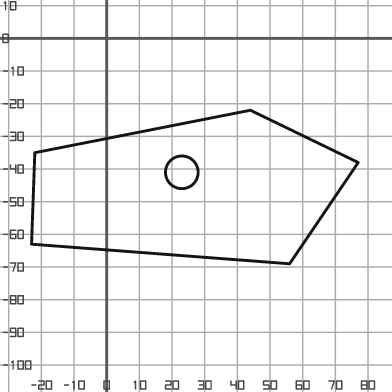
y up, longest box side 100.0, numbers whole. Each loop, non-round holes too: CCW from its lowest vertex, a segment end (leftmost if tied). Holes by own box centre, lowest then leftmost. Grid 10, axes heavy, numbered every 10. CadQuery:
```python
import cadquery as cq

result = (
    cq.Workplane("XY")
    .moveTo(56.0, -69.0)
    .lineTo(77.0, -38.0)
    .lineTo(44.0, -22.0)
    .lineTo(-22.0, -35.0)
    .lineTo(-23.0, -63.0)
    .close()
    .moveTo(23.0, -41.0)
    .circle(5.0)
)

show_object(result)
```